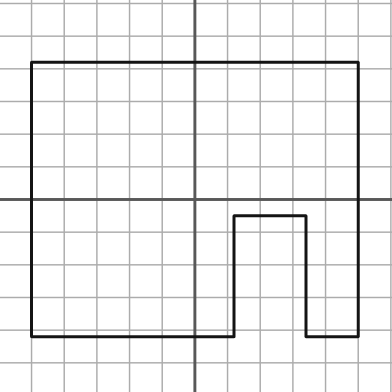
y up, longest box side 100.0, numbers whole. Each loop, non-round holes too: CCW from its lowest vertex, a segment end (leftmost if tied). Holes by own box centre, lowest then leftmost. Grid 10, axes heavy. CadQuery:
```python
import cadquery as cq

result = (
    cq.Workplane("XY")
    .moveTo(-50.0, -42.0)
    .lineTo(12.0, -42.0)
    .lineTo(12.0, -5.0)
    .lineTo(34.0, -5.0)
    .lineTo(34.0, -42.0)
    .lineTo(50.0, -42.0)
    .lineTo(50.0, 42.0)
    .lineTo(-50.0, 42.0)
    .close()
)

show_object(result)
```